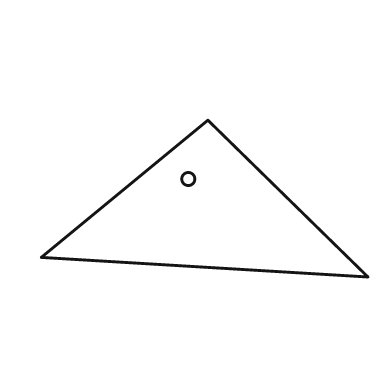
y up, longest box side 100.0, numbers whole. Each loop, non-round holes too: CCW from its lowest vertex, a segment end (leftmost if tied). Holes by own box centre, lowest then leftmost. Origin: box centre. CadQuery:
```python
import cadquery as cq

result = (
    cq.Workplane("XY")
    .moveTo(50.0, -24.0)
    .lineTo(1.0, 24.0)
    .lineTo(-50.0, -18.0)
    .close()
    .moveTo(-5.0, 6.0)
    .circle(2.0)
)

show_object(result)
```